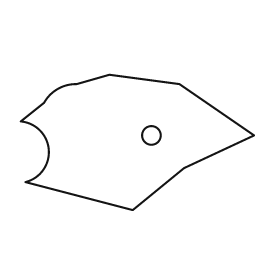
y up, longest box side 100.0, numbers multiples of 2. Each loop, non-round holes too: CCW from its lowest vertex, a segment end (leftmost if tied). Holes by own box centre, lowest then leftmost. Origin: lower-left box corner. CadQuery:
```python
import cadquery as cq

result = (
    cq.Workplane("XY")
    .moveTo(48.0, 0.0)
    .lineTo(70.0, 18.0)
    .lineTo(100.0, 32.0)
    .lineTo(68.0, 54.0)
    .lineTo(38.0, 58.0)
    .lineTo(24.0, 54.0)
    .threePointArc((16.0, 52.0), (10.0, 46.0))
    .lineTo(0.0, 38.0)
    .threePointArc((12.0, 26.0), (2.0, 12.0))
    .close()
    .moveTo(56.0, 32.0)
    .circle(4.0)
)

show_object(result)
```